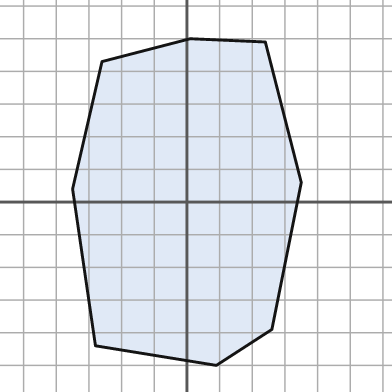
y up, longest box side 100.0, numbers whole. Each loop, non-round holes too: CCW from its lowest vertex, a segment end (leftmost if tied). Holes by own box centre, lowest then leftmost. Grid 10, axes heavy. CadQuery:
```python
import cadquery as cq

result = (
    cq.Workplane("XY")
    .moveTo(9.0, -50.0)
    .lineTo(26.0, -39.0)
    .lineTo(35.0, 6.0)
    .lineTo(24.0, 49.0)
    .lineTo(1.0, 50.0)
    .lineTo(-26.0, 43.0)
    .lineTo(-35.0, 4.0)
    .lineTo(-28.0, -44.0)
    .close()
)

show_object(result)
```